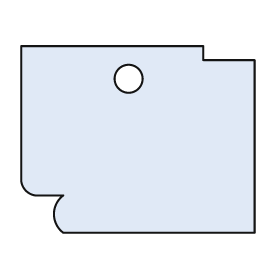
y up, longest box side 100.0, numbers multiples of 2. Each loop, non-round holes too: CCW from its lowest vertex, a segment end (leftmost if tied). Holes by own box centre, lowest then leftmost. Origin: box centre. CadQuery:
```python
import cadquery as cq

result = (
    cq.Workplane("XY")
    .moveTo(-32.0, -40.0)
    .lineTo(50.0, -40.0)
    .lineTo(50.0, 34.0)
    .lineTo(28.0, 34.0)
    .lineTo(28.0, 40.0)
    .lineTo(-50.0, 40.0)
    .lineTo(-50.0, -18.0)
    .threePointArc((-48.0, -22.0), (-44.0, -24.0))
    .lineTo(-32.0, -24.0)
    .threePointArc((-36.0, -32.0), (-32.0, -40.0))
    .close()
    .moveTo(-4.0, 26.0)
    .circle(6.0)
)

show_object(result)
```